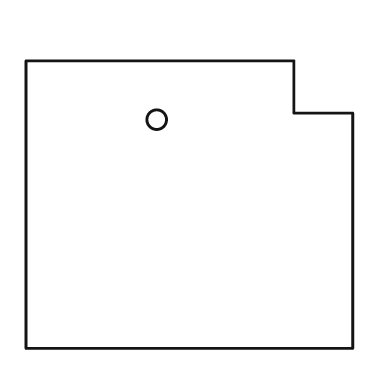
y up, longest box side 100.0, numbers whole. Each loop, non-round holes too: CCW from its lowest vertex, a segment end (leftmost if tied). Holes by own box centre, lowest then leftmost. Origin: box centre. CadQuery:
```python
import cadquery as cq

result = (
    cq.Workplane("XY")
    .moveTo(-50.0, -44.0)
    .lineTo(50.0, -44.0)
    .lineTo(50.0, 28.0)
    .lineTo(32.0, 28.0)
    .lineTo(32.0, 44.0)
    .lineTo(-50.0, 44.0)
    .close()
    .moveTo(-10.0, 26.0)
    .circle(3.0)
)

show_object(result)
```